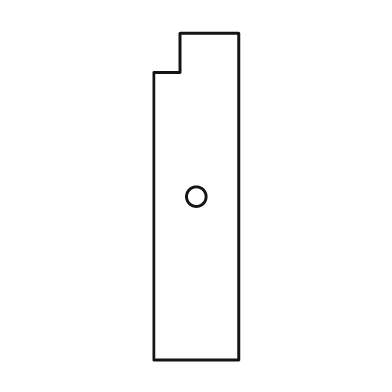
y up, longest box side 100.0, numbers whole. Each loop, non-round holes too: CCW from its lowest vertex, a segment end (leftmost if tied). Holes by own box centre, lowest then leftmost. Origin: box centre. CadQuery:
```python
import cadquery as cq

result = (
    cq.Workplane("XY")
    .moveTo(-13.0, -50.0)
    .lineTo(13.0, -50.0)
    .lineTo(13.0, 50.0)
    .lineTo(-5.0, 50.0)
    .lineTo(-5.0, 38.0)
    .lineTo(-13.0, 38.0)
    .close()
    .moveTo(0.0, 0.0)
    .circle(3.0)
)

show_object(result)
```